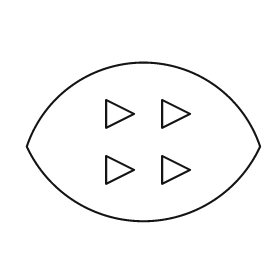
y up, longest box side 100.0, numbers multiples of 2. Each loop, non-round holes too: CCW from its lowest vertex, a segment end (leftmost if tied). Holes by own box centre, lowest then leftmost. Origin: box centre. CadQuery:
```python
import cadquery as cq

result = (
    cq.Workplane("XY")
    .moveTo(-50.0, -2.0)
    .threePointArc((0.0, -34.0), (50.0, -2.0))
    .threePointArc((0.0, 34.0), (-50.0, -2.0))
    .close()
    .moveTo(-16.0, -18.0)
    .lineTo(-4.0, -12.0)
    .lineTo(-16.0, -6.0)
    .close()
    .moveTo(8.0, -18.0)
    .lineTo(20.0, -12.0)
    .lineTo(8.0, -6.0)
    .close()
    .moveTo(-16.0, 6.0)
    .lineTo(-4.0, 12.0)
    .lineTo(-16.0, 18.0)
    .close()
    .moveTo(8.0, 6.0)
    .lineTo(20.0, 12.0)
    .lineTo(8.0, 18.0)
    .close()
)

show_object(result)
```